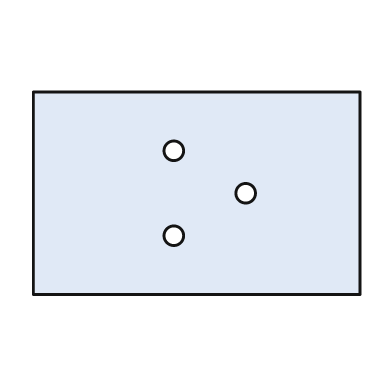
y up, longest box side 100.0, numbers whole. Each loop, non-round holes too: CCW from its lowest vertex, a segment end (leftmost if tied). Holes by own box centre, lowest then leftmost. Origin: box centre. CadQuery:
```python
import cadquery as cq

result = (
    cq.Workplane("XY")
    .moveTo(-50.0, -31.0)
    .lineTo(50.0, -31.0)
    .lineTo(50.0, 31.0)
    .lineTo(-50.0, 31.0)
    .close()
    .moveTo(-7.0, -13.0)
    .circle(3.0)
    .moveTo(15.0, 0.0)
    .circle(3.0)
    .moveTo(-7.0, 13.0)
    .circle(3.0)
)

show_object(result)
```